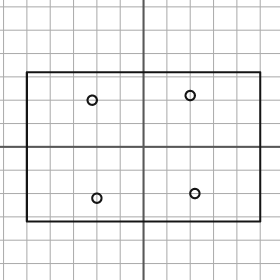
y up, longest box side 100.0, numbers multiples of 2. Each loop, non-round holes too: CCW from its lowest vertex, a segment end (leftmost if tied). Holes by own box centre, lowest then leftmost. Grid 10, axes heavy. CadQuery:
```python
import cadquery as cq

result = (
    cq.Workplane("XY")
    .moveTo(-50.0, -32.0)
    .lineTo(50.0, -32.0)
    .lineTo(50.0, 32.0)
    .lineTo(-50.0, 32.0)
    .close()
    .moveTo(-20.0, -22.0)
    .circle(2.0)
    .moveTo(22.0, -20.0)
    .circle(2.0)
    .moveTo(-22.0, 20.0)
    .circle(2.0)
    .moveTo(20.0, 22.0)
    .circle(2.0)
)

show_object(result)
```